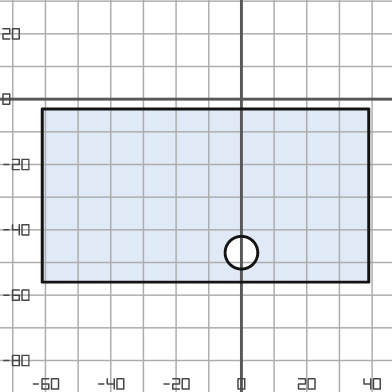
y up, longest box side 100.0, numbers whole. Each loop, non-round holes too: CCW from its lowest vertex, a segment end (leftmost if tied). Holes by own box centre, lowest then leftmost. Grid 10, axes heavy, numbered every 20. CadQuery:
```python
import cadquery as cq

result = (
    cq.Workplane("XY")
    .moveTo(-61.0, -56.0)
    .lineTo(39.0, -56.0)
    .lineTo(39.0, -3.0)
    .lineTo(-61.0, -3.0)
    .close()
    .moveTo(0.0, -47.0)
    .circle(5.0)
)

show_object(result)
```